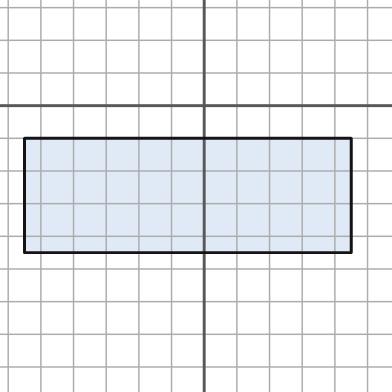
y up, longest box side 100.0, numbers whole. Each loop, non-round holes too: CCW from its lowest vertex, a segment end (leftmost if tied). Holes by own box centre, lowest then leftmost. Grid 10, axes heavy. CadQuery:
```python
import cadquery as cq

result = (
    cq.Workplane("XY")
    .moveTo(-55.0, -45.0)
    .lineTo(45.0, -45.0)
    .lineTo(45.0, -10.0)
    .lineTo(-55.0, -10.0)
    .close()
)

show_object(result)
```